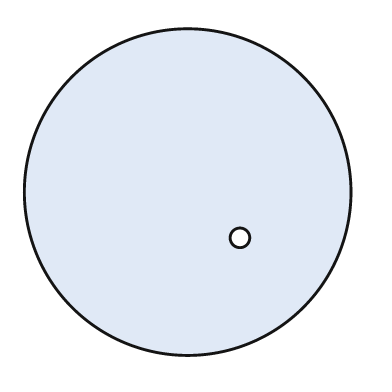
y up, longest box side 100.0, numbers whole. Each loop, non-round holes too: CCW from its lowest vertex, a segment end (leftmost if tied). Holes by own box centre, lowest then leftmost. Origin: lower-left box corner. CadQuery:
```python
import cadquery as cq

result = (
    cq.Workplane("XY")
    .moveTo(50.0, 50.0)
    .circle(50.0)
    .moveTo(66.0, 36.0)
    .circle(3.0)
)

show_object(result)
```